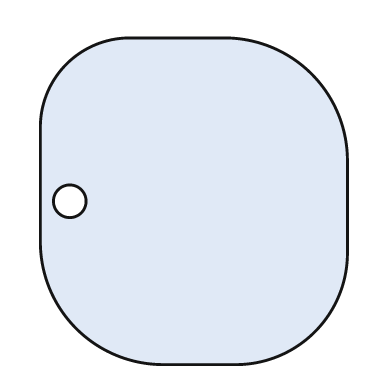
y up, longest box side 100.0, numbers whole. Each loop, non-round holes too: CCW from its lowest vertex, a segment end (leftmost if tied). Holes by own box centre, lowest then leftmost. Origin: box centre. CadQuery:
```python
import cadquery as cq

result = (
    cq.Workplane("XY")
    .moveTo(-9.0, -50.0)
    .lineTo(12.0, -50.0)
    .threePointArc((37.0, -40.0), (47.0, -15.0))
    .lineTo(47.0, 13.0)
    .threePointArc((36.0, 39.0), (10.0, 50.0))
    .lineTo(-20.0, 50.0)
    .threePointArc((-39.0, 42.0), (-47.0, 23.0))
    .lineTo(-47.0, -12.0)
    .threePointArc((-36.0, -39.0), (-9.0, -50.0))
    .close()
    .moveTo(-38.0, 0.0)
    .circle(5.0)
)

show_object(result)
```